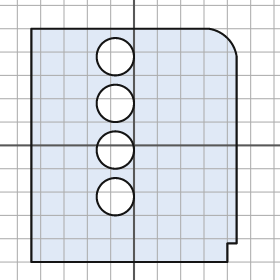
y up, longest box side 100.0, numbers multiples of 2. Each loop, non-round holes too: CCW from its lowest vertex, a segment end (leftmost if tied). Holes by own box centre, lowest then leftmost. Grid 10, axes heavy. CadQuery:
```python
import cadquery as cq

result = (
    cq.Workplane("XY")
    .moveTo(-44.0, -50.0)
    .lineTo(40.0, -50.0)
    .lineTo(40.0, -42.0)
    .lineTo(44.0, -42.0)
    .lineTo(44.0, 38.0)
    .threePointArc((40.0, 46.0), (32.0, 50.0))
    .lineTo(-44.0, 50.0)
    .close()
    .moveTo(-8.0, -22.0)
    .circle(8.0)
    .moveTo(-8.0, -2.0)
    .circle(8.0)
    .moveTo(-8.0, 18.0)
    .circle(8.0)
    .moveTo(-8.0, 38.0)
    .circle(8.0)
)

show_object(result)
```